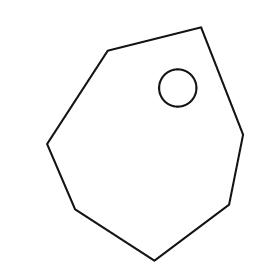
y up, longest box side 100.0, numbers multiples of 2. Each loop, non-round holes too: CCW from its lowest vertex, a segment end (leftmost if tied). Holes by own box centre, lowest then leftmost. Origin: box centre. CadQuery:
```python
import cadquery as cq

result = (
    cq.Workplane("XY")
    .moveTo(4.0, -50.0)
    .lineTo(36.0, -26.0)
    .lineTo(42.0, 4.0)
    .lineTo(24.0, 50.0)
    .lineTo(-16.0, 40.0)
    .lineTo(-42.0, 0.0)
    .lineTo(-30.0, -28.0)
    .close()
    .moveTo(14.0, 24.0)
    .circle(8.0)
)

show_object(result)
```